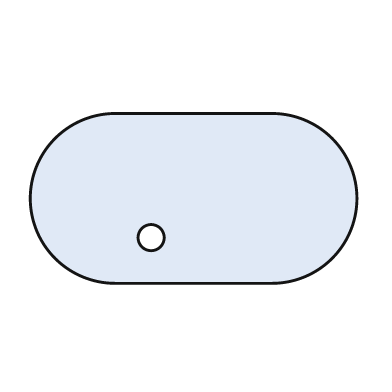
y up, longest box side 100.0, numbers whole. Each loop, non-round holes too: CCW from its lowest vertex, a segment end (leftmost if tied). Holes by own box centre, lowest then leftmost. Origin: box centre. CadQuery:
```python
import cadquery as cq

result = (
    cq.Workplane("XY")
    .moveTo(-24.0, -26.0)
    .lineTo(24.0, -26.0)
    .threePointArc((50.0, 0.0), (24.0, 26.0))
    .lineTo(-24.0, 26.0)
    .threePointArc((-50.0, 0.0), (-24.0, -26.0))
    .close()
    .moveTo(-13.0, -12.0)
    .circle(4.0)
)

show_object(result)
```